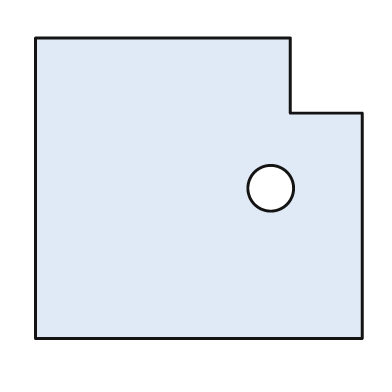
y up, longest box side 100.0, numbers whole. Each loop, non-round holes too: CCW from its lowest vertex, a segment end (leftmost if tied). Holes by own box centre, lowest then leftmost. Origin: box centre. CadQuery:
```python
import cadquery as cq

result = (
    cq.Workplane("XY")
    .moveTo(-50.0, -46.0)
    .lineTo(50.0, -46.0)
    .lineTo(50.0, 23.0)
    .lineTo(28.0, 23.0)
    .lineTo(28.0, 46.0)
    .lineTo(-50.0, 46.0)
    .close()
    .moveTo(22.0, 0.0)
    .circle(7.0)
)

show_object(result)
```